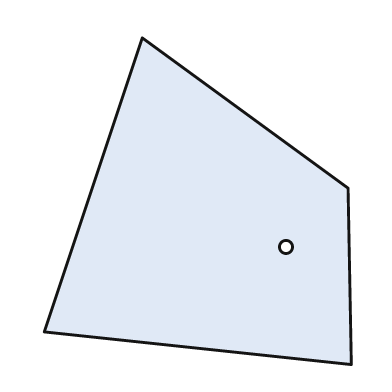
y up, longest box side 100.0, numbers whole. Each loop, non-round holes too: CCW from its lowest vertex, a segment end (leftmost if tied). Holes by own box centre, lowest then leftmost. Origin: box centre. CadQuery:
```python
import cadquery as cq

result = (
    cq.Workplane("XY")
    .moveTo(47.0, -50.0)
    .lineTo(46.0, 4.0)
    .lineTo(-17.0, 50.0)
    .lineTo(-47.0, -40.0)
    .close()
    .moveTo(27.0, -14.0)
    .circle(2.0)
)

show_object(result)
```